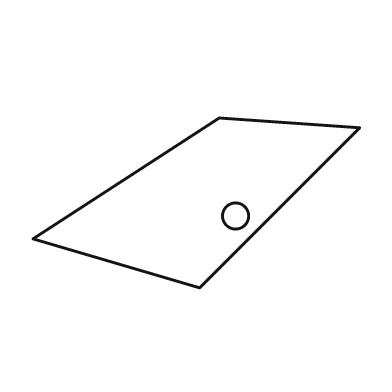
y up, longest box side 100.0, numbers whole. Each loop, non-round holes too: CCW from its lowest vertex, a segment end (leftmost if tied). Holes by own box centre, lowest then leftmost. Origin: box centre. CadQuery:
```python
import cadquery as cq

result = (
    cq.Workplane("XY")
    .moveTo(1.0, -26.0)
    .lineTo(50.0, 23.0)
    .lineTo(7.0, 26.0)
    .lineTo(-50.0, -11.0)
    .close()
    .moveTo(12.0, -4.0)
    .circle(4.0)
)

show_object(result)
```